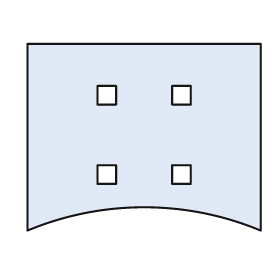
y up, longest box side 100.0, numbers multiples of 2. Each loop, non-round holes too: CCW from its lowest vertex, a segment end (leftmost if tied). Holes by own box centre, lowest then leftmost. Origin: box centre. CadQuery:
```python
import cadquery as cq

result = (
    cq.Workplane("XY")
    .moveTo(-50.0, -40.0)
    .threePointArc((0.0, -30.0), (50.0, -40.0))
    .lineTo(50.0, 40.0)
    .lineTo(-50.0, 40.0)
    .close()
    .moveTo(-20.0, -20.0)
    .lineTo(-12.0, -20.0)
    .lineTo(-12.0, -12.0)
    .lineTo(-20.0, -12.0)
    .close()
    .moveTo(12.0, -20.0)
    .lineTo(20.0, -20.0)
    .lineTo(20.0, -12.0)
    .lineTo(12.0, -12.0)
    .close()
    .moveTo(-20.0, 14.0)
    .lineTo(-12.0, 14.0)
    .lineTo(-12.0, 22.0)
    .lineTo(-20.0, 22.0)
    .close()
    .moveTo(12.0, 14.0)
    .lineTo(20.0, 14.0)
    .lineTo(20.0, 22.0)
    .lineTo(12.0, 22.0)
    .close()
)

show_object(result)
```